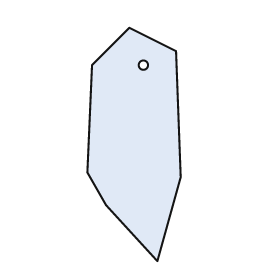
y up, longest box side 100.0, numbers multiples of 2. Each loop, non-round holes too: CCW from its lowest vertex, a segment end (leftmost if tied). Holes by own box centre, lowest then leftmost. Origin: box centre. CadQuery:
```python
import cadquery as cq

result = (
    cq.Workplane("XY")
    .moveTo(10.0, -50.0)
    .lineTo(20.0, -14.0)
    .lineTo(18.0, 40.0)
    .lineTo(-2.0, 50.0)
    .lineTo(-18.0, 34.0)
    .lineTo(-20.0, -12.0)
    .lineTo(-12.0, -26.0)
    .close()
    .moveTo(4.0, 34.0)
    .circle(2.0)
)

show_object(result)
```